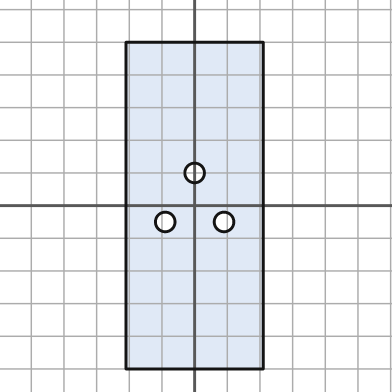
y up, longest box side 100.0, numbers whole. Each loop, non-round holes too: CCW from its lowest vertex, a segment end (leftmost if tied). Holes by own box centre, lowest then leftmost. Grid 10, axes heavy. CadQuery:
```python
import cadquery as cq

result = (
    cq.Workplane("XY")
    .moveTo(-21.0, -50.0)
    .lineTo(21.0, -50.0)
    .lineTo(21.0, 50.0)
    .lineTo(-21.0, 50.0)
    .close()
    .moveTo(-9.0, -5.0)
    .circle(3.0)
    .moveTo(9.0, -5.0)
    .circle(3.0)
    .moveTo(0.0, 10.0)
    .circle(3.0)
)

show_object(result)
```